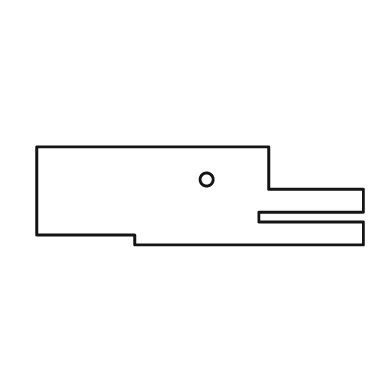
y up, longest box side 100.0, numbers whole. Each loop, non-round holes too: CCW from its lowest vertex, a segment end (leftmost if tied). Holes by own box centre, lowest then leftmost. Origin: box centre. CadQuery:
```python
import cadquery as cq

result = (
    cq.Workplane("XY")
    .moveTo(-20.0, -15.0)
    .lineTo(50.0, -15.0)
    .lineTo(50.0, -8.0)
    .lineTo(18.0, -8.0)
    .lineTo(18.0, -5.0)
    .lineTo(50.0, -5.0)
    .lineTo(50.0, 2.0)
    .lineTo(21.0, 2.0)
    .lineTo(21.0, 15.0)
    .lineTo(-50.0, 15.0)
    .lineTo(-50.0, -12.0)
    .lineTo(-20.0, -12.0)
    .close()
    .moveTo(2.0, 5.0)
    .circle(2.0)
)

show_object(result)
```